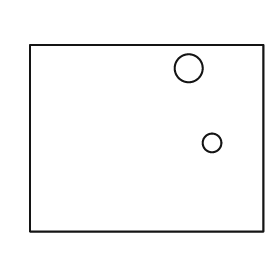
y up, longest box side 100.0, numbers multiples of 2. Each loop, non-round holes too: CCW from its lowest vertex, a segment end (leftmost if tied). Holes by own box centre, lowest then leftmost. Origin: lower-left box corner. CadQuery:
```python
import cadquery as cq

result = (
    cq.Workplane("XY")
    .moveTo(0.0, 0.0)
    .lineTo(100.0, 0.0)
    .lineTo(100.0, 80.0)
    .lineTo(0.0, 80.0)
    .close()
    .moveTo(78.0, 38.0)
    .circle(4.0)
    .moveTo(68.0, 70.0)
    .circle(6.0)
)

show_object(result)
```